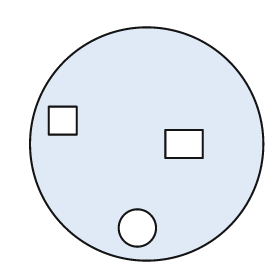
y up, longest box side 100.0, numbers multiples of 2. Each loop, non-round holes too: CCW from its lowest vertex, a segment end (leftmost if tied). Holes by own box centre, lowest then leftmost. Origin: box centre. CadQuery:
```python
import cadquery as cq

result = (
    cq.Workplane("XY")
    .moveTo(0.0, 0.0)
    .circle(50.0)
    .moveTo(-4.0, -36.0)
    .circle(8.0)
    .moveTo(8.0, -6.0)
    .lineTo(24.0, -6.0)
    .lineTo(24.0, 6.0)
    .lineTo(8.0, 6.0)
    .close()
    .moveTo(-42.0, 4.0)
    .lineTo(-30.0, 4.0)
    .lineTo(-30.0, 16.0)
    .lineTo(-42.0, 16.0)
    .close()
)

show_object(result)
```